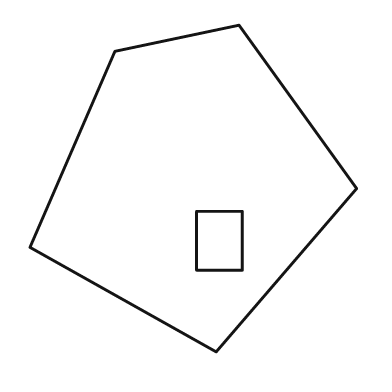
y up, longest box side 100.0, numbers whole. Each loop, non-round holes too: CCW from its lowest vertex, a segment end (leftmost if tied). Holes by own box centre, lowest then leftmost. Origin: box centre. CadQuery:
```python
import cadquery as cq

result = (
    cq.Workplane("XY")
    .moveTo(7.0, -50.0)
    .lineTo(50.0, 0.0)
    .lineTo(14.0, 50.0)
    .lineTo(-24.0, 42.0)
    .lineTo(-50.0, -18.0)
    .close()
    .moveTo(1.0, -25.0)
    .lineTo(15.0, -25.0)
    .lineTo(15.0, -7.0)
    .lineTo(1.0, -7.0)
    .close()
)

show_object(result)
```